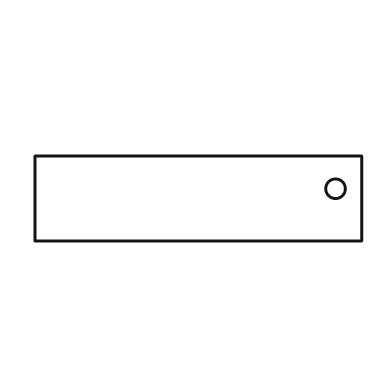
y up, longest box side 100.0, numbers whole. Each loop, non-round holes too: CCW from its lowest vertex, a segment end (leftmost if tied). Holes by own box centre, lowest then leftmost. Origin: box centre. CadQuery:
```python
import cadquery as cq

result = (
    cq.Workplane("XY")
    .moveTo(-50.0, -13.0)
    .lineTo(50.0, -13.0)
    .lineTo(50.0, 13.0)
    .lineTo(-50.0, 13.0)
    .close()
    .moveTo(42.0, 3.0)
    .circle(3.0)
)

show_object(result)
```